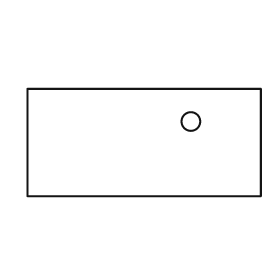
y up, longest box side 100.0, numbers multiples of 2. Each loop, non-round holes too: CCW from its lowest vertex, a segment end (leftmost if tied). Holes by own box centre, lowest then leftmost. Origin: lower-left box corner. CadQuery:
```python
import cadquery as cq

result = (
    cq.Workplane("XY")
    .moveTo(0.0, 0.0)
    .lineTo(100.0, 0.0)
    .lineTo(100.0, 46.0)
    .lineTo(0.0, 46.0)
    .close()
    .moveTo(70.0, 32.0)
    .circle(4.0)
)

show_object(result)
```